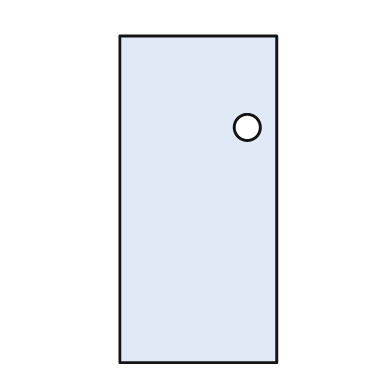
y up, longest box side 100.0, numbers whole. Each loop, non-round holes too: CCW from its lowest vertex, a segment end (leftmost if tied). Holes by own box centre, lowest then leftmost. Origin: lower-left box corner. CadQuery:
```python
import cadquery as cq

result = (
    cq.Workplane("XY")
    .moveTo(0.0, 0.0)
    .lineTo(48.0, 0.0)
    .lineTo(48.0, 100.0)
    .lineTo(0.0, 100.0)
    .close()
    .moveTo(39.0, 72.0)
    .circle(4.0)
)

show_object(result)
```